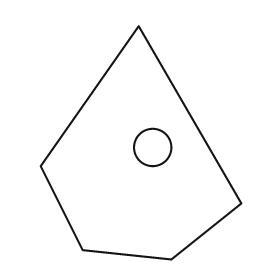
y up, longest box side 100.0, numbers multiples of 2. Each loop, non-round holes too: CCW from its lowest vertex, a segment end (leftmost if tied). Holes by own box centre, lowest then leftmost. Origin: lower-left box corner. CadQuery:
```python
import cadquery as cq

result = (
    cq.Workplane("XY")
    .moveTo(56.0, 0.0)
    .lineTo(86.0, 24.0)
    .lineTo(42.0, 100.0)
    .lineTo(0.0, 40.0)
    .lineTo(18.0, 4.0)
    .close()
    .moveTo(48.0, 48.0)
    .circle(8.0)
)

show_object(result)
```